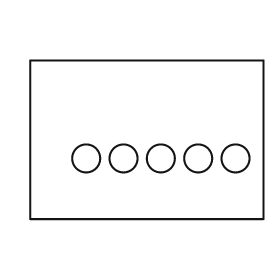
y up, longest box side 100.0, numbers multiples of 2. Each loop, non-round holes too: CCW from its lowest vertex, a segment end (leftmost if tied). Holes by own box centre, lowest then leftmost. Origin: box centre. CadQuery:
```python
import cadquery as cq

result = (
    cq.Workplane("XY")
    .moveTo(-50.0, -34.0)
    .lineTo(50.0, -34.0)
    .lineTo(50.0, 34.0)
    .lineTo(-50.0, 34.0)
    .close()
    .moveTo(-26.0, -8.0)
    .circle(6.0)
    .moveTo(-10.0, -8.0)
    .circle(6.0)
    .moveTo(6.0, -8.0)
    .circle(6.0)
    .moveTo(22.0, -8.0)
    .circle(6.0)
    .moveTo(38.0, -8.0)
    .circle(6.0)
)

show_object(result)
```